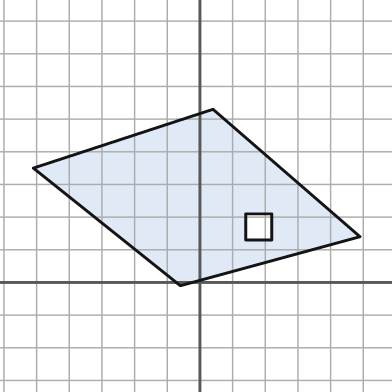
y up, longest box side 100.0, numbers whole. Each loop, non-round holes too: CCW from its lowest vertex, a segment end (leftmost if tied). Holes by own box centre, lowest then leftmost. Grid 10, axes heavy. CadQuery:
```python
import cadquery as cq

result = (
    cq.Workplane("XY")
    .moveTo(-6.0, -1.0)
    .lineTo(49.0, 14.0)
    .lineTo(4.0, 53.0)
    .lineTo(-51.0, 35.0)
    .close()
    .moveTo(14.0, 13.0)
    .lineTo(22.0, 13.0)
    .lineTo(22.0, 21.0)
    .lineTo(14.0, 21.0)
    .close()
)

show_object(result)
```